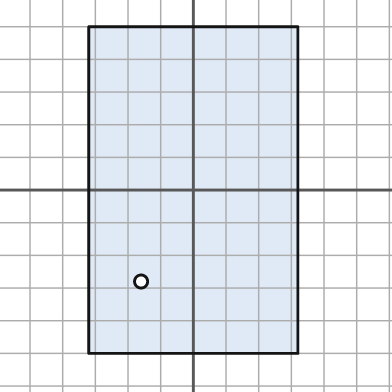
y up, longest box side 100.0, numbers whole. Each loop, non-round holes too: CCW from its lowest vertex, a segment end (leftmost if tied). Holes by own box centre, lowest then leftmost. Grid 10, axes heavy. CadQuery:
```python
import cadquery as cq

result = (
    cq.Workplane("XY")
    .moveTo(-32.0, -50.0)
    .lineTo(32.0, -50.0)
    .lineTo(32.0, 50.0)
    .lineTo(-32.0, 50.0)
    .close()
    .moveTo(-16.0, -28.0)
    .circle(2.0)
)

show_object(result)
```